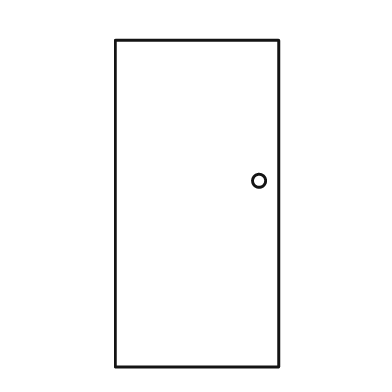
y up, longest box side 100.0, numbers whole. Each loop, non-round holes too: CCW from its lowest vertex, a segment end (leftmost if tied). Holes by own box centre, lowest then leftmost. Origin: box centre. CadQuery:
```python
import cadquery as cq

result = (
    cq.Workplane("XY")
    .moveTo(-25.0, -50.0)
    .lineTo(25.0, -50.0)
    .lineTo(25.0, 50.0)
    .lineTo(-25.0, 50.0)
    .close()
    .moveTo(19.0, 7.0)
    .circle(2.0)
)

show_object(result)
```